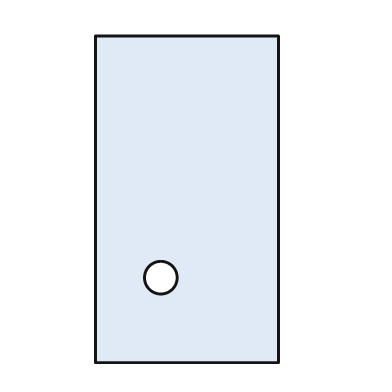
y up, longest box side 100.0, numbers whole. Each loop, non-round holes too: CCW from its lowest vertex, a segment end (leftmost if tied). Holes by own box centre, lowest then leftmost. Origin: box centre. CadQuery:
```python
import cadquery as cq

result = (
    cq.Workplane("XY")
    .moveTo(-28.0, -50.0)
    .lineTo(28.0, -50.0)
    .lineTo(28.0, 50.0)
    .lineTo(-28.0, 50.0)
    .close()
    .moveTo(-8.0, -24.0)
    .circle(5.0)
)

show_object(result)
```